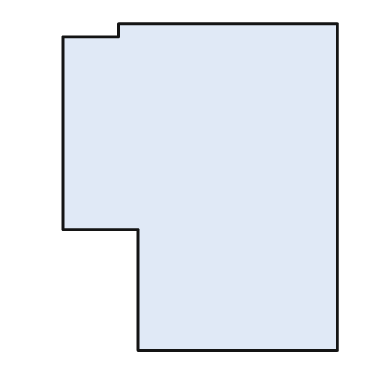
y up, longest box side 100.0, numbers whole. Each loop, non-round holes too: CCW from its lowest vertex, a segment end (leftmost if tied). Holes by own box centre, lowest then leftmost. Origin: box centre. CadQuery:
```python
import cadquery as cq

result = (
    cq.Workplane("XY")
    .moveTo(-19.0, -50.0)
    .lineTo(42.0, -50.0)
    .lineTo(42.0, 50.0)
    .lineTo(-25.0, 50.0)
    .lineTo(-25.0, 46.0)
    .lineTo(-42.0, 46.0)
    .lineTo(-42.0, -13.0)
    .lineTo(-19.0, -13.0)
    .close()
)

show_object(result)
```